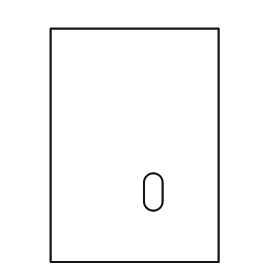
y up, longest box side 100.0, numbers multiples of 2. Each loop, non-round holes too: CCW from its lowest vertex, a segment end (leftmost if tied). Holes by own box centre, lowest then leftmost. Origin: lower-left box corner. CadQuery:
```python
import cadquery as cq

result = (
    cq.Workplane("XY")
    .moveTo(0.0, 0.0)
    .lineTo(72.0, 0.0)
    .lineTo(72.0, 100.0)
    .lineTo(0.0, 100.0)
    .close()
    .moveTo(40.0, 26.0)
    .threePointArc((44.0, 22.0), (48.0, 26.0))
    .lineTo(48.0, 34.0)
    .threePointArc((44.0, 38.0), (40.0, 34.0))
    .close()
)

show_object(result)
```